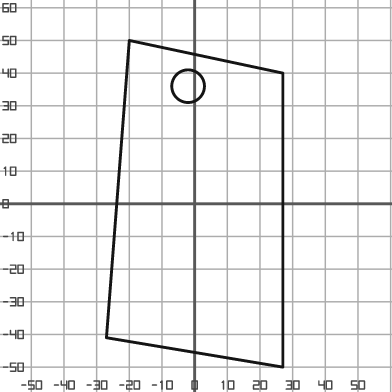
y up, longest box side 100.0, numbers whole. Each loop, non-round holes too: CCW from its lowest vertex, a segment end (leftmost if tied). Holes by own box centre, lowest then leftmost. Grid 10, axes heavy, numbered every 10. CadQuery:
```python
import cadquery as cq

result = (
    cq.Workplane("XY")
    .moveTo(27.0, -50.0)
    .lineTo(27.0, 40.0)
    .lineTo(-20.0, 50.0)
    .lineTo(-27.0, -41.0)
    .close()
    .moveTo(-2.0, 36.0)
    .circle(5.0)
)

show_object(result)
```